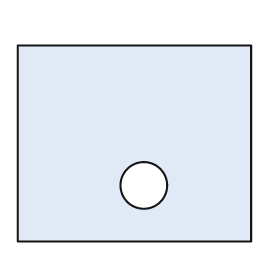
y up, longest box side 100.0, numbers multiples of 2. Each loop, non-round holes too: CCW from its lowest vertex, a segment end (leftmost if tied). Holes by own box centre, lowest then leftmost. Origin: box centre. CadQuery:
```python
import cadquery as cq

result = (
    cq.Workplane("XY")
    .moveTo(-50.0, -42.0)
    .lineTo(50.0, -42.0)
    .lineTo(50.0, 42.0)
    .lineTo(-50.0, 42.0)
    .close()
    .moveTo(4.0, -18.0)
    .circle(10.0)
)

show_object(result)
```